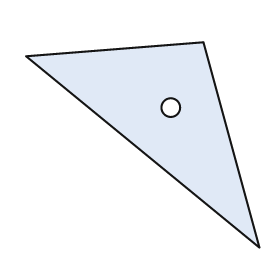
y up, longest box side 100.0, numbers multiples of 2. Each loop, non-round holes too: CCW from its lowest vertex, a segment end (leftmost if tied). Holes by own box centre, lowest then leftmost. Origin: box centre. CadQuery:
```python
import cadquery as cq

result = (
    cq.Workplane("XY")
    .moveTo(50.0, -44.0)
    .lineTo(26.0, 44.0)
    .lineTo(-50.0, 38.0)
    .close()
    .moveTo(12.0, 16.0)
    .circle(4.0)
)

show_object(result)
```